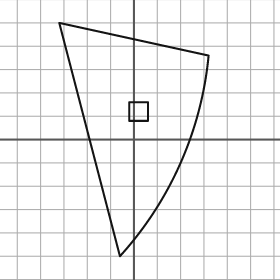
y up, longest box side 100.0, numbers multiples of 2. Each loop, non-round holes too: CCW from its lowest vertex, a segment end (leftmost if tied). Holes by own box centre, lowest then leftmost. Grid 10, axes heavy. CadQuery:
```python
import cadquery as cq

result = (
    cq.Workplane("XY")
    .moveTo(-6.0, -50.0)
    .threePointArc((20.0, -10.0), (32.0, 36.0))
    .lineTo(-32.0, 50.0)
    .close()
    .moveTo(-2.0, 8.0)
    .lineTo(6.0, 8.0)
    .lineTo(6.0, 16.0)
    .lineTo(-2.0, 16.0)
    .close()
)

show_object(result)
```